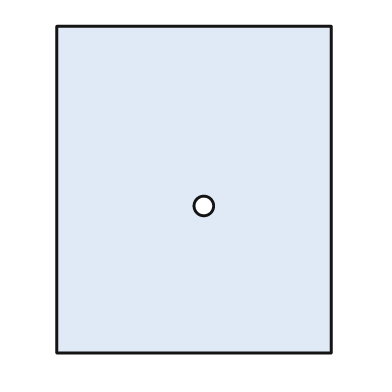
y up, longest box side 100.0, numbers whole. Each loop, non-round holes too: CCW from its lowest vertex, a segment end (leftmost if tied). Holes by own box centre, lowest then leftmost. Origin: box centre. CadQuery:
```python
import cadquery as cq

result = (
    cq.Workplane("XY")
    .moveTo(-42.0, -50.0)
    .lineTo(42.0, -50.0)
    .lineTo(42.0, 50.0)
    .lineTo(-42.0, 50.0)
    .close()
    .moveTo(3.0, -5.0)
    .circle(3.0)
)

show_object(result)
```